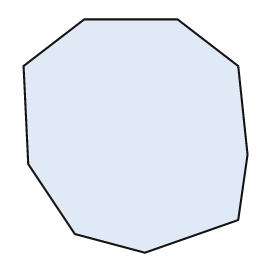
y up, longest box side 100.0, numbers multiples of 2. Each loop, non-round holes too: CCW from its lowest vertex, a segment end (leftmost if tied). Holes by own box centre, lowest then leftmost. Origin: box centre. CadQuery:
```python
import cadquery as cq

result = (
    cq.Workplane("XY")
    .moveTo(4.0, -50.0)
    .lineTo(44.0, -36.0)
    .lineTo(48.0, -8.0)
    .lineTo(44.0, 30.0)
    .lineTo(18.0, 50.0)
    .lineTo(-22.0, 50.0)
    .lineTo(-48.0, 30.0)
    .lineTo(-46.0, -12.0)
    .lineTo(-26.0, -42.0)
    .close()
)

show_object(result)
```